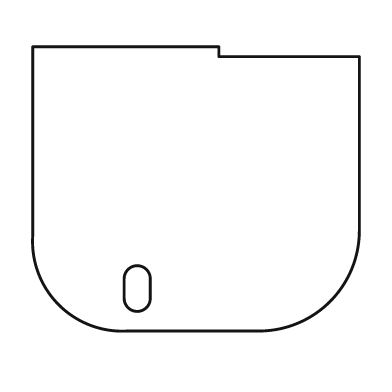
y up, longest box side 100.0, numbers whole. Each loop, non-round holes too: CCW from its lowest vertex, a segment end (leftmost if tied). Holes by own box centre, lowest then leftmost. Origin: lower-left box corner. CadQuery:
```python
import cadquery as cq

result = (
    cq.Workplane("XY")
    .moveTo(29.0, 0.0)
    .lineTo(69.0, 0.0)
    .threePointArc((91.0, 9.0), (100.0, 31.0))
    .lineTo(100.0, 84.0)
    .lineTo(57.0, 84.0)
    .lineTo(57.0, 87.0)
    .lineTo(0.0, 87.0)
    .lineTo(0.0, 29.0)
    .threePointArc((8.0, 8.0), (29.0, 0.0))
    .close()
    .moveTo(28.0, 10.0)
    .threePointArc((32.0, 6.0), (36.0, 10.0))
    .lineTo(36.0, 16.0)
    .threePointArc((32.0, 20.0), (28.0, 16.0))
    .close()
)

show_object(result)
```